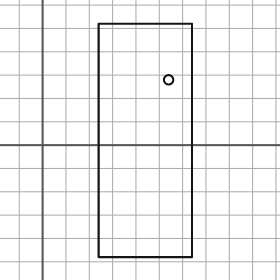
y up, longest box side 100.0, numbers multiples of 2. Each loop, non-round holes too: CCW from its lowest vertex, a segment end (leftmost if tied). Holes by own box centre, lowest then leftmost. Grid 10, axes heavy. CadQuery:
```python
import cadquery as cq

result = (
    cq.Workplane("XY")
    .moveTo(24.0, -48.0)
    .lineTo(64.0, -48.0)
    .lineTo(64.0, 52.0)
    .lineTo(24.0, 52.0)
    .close()
    .moveTo(54.0, 28.0)
    .circle(2.0)
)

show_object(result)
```